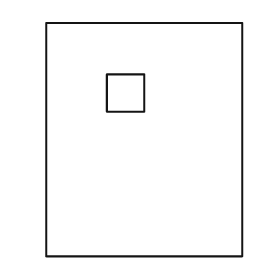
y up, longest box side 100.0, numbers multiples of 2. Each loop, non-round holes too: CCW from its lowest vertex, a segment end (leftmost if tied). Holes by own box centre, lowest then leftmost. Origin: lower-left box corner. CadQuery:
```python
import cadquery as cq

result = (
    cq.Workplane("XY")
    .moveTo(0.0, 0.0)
    .lineTo(84.0, 0.0)
    .lineTo(84.0, 100.0)
    .lineTo(0.0, 100.0)
    .close()
    .moveTo(26.0, 62.0)
    .lineTo(42.0, 62.0)
    .lineTo(42.0, 78.0)
    .lineTo(26.0, 78.0)
    .close()
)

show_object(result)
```